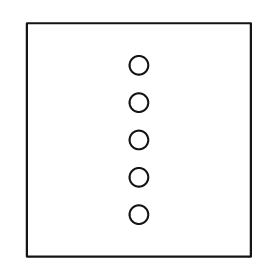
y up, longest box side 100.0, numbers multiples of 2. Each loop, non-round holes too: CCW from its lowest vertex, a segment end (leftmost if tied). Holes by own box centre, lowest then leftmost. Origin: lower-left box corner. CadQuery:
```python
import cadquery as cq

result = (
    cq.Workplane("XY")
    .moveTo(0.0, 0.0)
    .lineTo(96.0, 0.0)
    .lineTo(96.0, 100.0)
    .lineTo(0.0, 100.0)
    .close()
    .moveTo(48.0, 18.0)
    .circle(4.0)
    .moveTo(48.0, 34.0)
    .circle(4.0)
    .moveTo(48.0, 50.0)
    .circle(4.0)
    .moveTo(48.0, 66.0)
    .circle(4.0)
    .moveTo(48.0, 82.0)
    .circle(4.0)
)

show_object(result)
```